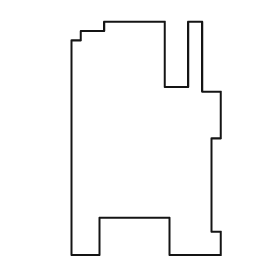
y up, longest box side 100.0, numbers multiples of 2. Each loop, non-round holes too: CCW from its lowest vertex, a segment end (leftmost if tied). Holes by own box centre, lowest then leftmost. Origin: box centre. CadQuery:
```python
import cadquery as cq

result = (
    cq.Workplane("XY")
    .moveTo(-32.0, -50.0)
    .lineTo(-20.0, -50.0)
    .lineTo(-20.0, -34.0)
    .lineTo(10.0, -34.0)
    .lineTo(10.0, -50.0)
    .lineTo(32.0, -50.0)
    .lineTo(32.0, -40.0)
    .lineTo(28.0, -40.0)
    .lineTo(28.0, 0.0)
    .lineTo(32.0, 0.0)
    .lineTo(32.0, 20.0)
    .lineTo(24.0, 20.0)
    .lineTo(24.0, 50.0)
    .lineTo(18.0, 50.0)
    .lineTo(18.0, 22.0)
    .lineTo(8.0, 22.0)
    .lineTo(8.0, 50.0)
    .lineTo(-18.0, 50.0)
    .lineTo(-18.0, 46.0)
    .lineTo(-28.0, 46.0)
    .lineTo(-28.0, 42.0)
    .lineTo(-32.0, 42.0)
    .close()
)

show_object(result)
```